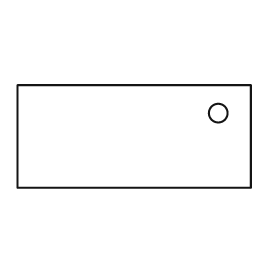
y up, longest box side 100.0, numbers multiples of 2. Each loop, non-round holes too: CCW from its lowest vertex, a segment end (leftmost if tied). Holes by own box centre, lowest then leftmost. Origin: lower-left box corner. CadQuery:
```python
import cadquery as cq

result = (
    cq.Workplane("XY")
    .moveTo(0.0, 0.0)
    .lineTo(100.0, 0.0)
    .lineTo(100.0, 44.0)
    .lineTo(0.0, 44.0)
    .close()
    .moveTo(86.0, 32.0)
    .circle(4.0)
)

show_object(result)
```